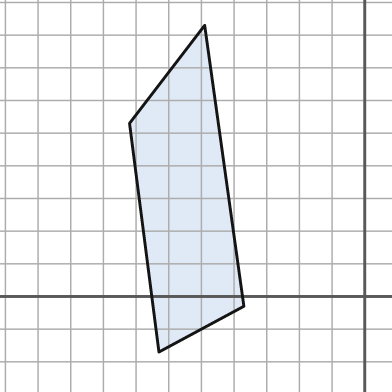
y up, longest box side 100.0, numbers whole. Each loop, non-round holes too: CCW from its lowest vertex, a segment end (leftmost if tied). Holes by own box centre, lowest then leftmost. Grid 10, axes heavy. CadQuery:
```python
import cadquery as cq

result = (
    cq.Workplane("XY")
    .moveTo(-63.0, -17.0)
    .lineTo(-37.0, -3.0)
    .lineTo(-49.0, 83.0)
    .lineTo(-72.0, 53.0)
    .close()
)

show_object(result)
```